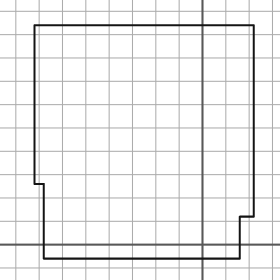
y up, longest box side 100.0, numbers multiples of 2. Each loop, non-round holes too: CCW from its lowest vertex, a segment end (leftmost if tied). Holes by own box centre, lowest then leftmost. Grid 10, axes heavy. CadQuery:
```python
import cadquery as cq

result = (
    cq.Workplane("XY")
    .moveTo(-68.0, -6.0)
    .lineTo(16.0, -6.0)
    .lineTo(16.0, 12.0)
    .lineTo(22.0, 12.0)
    .lineTo(22.0, 94.0)
    .lineTo(-72.0, 94.0)
    .lineTo(-72.0, 26.0)
    .lineTo(-68.0, 26.0)
    .close()
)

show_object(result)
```